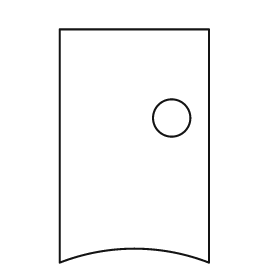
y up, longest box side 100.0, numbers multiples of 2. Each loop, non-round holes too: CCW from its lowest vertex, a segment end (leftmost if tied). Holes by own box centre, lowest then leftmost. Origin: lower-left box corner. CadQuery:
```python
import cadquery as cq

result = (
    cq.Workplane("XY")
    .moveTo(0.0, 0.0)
    .threePointArc((32.0, 6.0), (64.0, 0.0))
    .lineTo(64.0, 100.0)
    .lineTo(0.0, 100.0)
    .close()
    .moveTo(48.0, 62.0)
    .circle(8.0)
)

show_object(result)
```